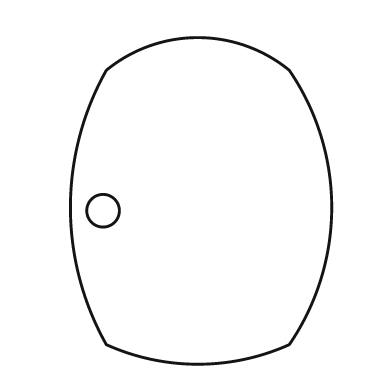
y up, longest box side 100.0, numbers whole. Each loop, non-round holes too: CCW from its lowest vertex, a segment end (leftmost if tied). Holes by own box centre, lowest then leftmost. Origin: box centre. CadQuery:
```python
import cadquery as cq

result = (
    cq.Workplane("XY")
    .moveTo(-29.0, -44.0)
    .threePointArc((-1.0, -50.0), (27.0, -44.0))
    .threePointArc((40.0, -2.0), (27.0, 40.0))
    .threePointArc((-1.0, 50.0), (-29.0, 40.0))
    .threePointArc((-40.0, -2.0), (-29.0, -44.0))
    .close()
    .moveTo(-30.0, -3.0)
    .circle(5.0)
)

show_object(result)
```